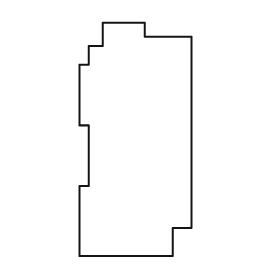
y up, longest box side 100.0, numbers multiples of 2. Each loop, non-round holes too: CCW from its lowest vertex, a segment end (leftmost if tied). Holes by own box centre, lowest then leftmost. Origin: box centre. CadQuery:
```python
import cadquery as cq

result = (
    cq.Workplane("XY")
    .moveTo(-24.0, -50.0)
    .lineTo(16.0, -50.0)
    .lineTo(16.0, -38.0)
    .lineTo(24.0, -38.0)
    .lineTo(24.0, 44.0)
    .lineTo(4.0, 44.0)
    .lineTo(4.0, 50.0)
    .lineTo(-14.0, 50.0)
    .lineTo(-14.0, 40.0)
    .lineTo(-20.0, 40.0)
    .lineTo(-20.0, 32.0)
    .lineTo(-24.0, 32.0)
    .lineTo(-24.0, 6.0)
    .lineTo(-20.0, 6.0)
    .lineTo(-20.0, -20.0)
    .lineTo(-24.0, -20.0)
    .close()
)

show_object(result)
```